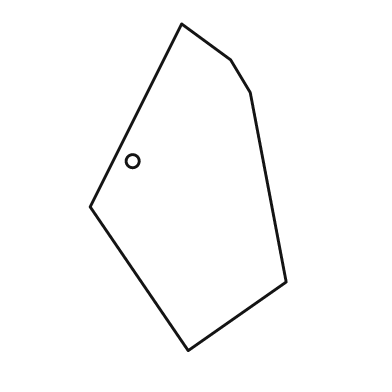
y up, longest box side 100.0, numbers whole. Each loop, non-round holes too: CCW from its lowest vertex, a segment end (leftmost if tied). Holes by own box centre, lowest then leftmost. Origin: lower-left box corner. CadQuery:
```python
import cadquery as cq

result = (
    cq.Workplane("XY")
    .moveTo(30.0, 0.0)
    .lineTo(60.0, 21.0)
    .lineTo(49.0, 79.0)
    .lineTo(43.0, 89.0)
    .lineTo(28.0, 100.0)
    .lineTo(0.0, 44.0)
    .close()
    .moveTo(13.0, 58.0)
    .circle(2.0)
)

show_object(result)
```